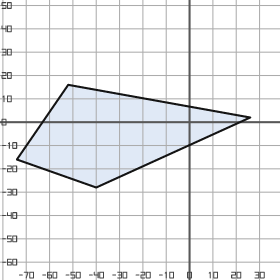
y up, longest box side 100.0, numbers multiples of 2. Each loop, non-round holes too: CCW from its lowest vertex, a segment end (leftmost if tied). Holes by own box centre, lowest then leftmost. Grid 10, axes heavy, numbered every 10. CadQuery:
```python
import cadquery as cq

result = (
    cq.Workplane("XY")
    .moveTo(-40.0, -28.0)
    .lineTo(26.0, 2.0)
    .lineTo(-52.0, 16.0)
    .lineTo(-74.0, -16.0)
    .close()
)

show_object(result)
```